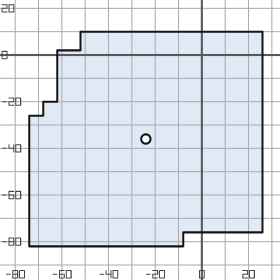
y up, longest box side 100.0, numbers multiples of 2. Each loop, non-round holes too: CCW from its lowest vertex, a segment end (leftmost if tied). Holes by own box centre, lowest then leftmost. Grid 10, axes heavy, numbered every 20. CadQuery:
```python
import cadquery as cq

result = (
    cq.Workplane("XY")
    .moveTo(-74.0, -82.0)
    .lineTo(-8.0, -82.0)
    .lineTo(-8.0, -76.0)
    .lineTo(26.0, -76.0)
    .lineTo(26.0, 10.0)
    .lineTo(-52.0, 10.0)
    .lineTo(-52.0, 2.0)
    .lineTo(-62.0, 2.0)
    .lineTo(-62.0, -20.0)
    .lineTo(-68.0, -20.0)
    .lineTo(-68.0, -26.0)
    .lineTo(-74.0, -26.0)
    .close()
    .moveTo(-24.0, -36.0)
    .circle(2.0)
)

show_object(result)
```